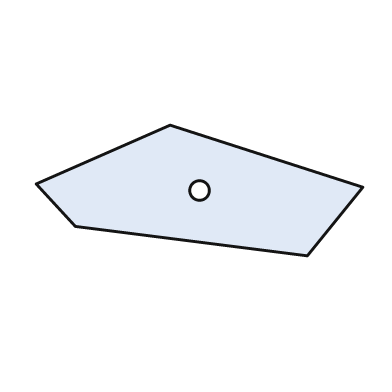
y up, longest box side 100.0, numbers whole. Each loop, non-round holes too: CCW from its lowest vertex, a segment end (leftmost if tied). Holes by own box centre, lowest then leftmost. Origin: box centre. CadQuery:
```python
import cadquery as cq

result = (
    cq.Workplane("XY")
    .moveTo(33.0, -20.0)
    .lineTo(50.0, 1.0)
    .lineTo(-9.0, 20.0)
    .lineTo(-50.0, 2.0)
    .lineTo(-38.0, -11.0)
    .close()
    .moveTo(0.0, 0.0)
    .circle(3.0)
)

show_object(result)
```